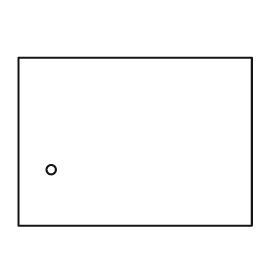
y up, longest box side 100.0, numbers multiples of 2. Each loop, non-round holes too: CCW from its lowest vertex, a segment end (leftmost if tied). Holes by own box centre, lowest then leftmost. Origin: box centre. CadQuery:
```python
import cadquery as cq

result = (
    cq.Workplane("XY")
    .moveTo(-50.0, -36.0)
    .lineTo(50.0, -36.0)
    .lineTo(50.0, 36.0)
    .lineTo(-50.0, 36.0)
    .close()
    .moveTo(-36.0, -12.0)
    .circle(2.0)
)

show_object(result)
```